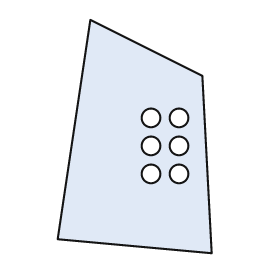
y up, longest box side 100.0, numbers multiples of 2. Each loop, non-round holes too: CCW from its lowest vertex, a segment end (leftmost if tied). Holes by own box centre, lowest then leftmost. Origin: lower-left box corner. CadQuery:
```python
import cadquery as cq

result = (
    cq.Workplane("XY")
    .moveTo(66.0, 0.0)
    .lineTo(62.0, 76.0)
    .lineTo(14.0, 100.0)
    .lineTo(0.0, 6.0)
    .close()
    .moveTo(40.0, 34.0)
    .circle(4.0)
    .moveTo(52.0, 34.0)
    .circle(4.0)
    .moveTo(40.0, 46.0)
    .circle(4.0)
    .moveTo(52.0, 46.0)
    .circle(4.0)
    .moveTo(40.0, 58.0)
    .circle(4.0)
    .moveTo(52.0, 58.0)
    .circle(4.0)
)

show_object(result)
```